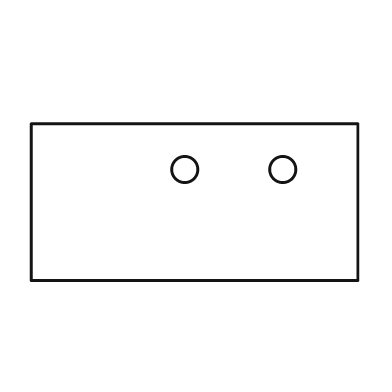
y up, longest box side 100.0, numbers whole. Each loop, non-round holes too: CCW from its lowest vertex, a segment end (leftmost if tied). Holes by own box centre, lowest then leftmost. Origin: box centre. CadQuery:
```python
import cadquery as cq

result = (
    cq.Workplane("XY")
    .moveTo(-50.0, -24.0)
    .lineTo(50.0, -24.0)
    .lineTo(50.0, 24.0)
    .lineTo(-50.0, 24.0)
    .close()
    .moveTo(-3.0, 10.0)
    .circle(4.0)
    .moveTo(27.0, 10.0)
    .circle(4.0)
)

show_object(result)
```